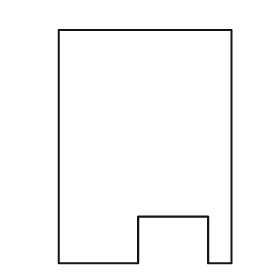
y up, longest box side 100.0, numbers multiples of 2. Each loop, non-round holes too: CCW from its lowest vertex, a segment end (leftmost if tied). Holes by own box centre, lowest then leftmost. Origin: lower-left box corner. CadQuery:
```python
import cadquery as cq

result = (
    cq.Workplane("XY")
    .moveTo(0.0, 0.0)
    .lineTo(34.0, 0.0)
    .lineTo(34.0, 20.0)
    .lineTo(64.0, 20.0)
    .lineTo(64.0, 0.0)
    .lineTo(74.0, 0.0)
    .lineTo(74.0, 100.0)
    .lineTo(0.0, 100.0)
    .close()
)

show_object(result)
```